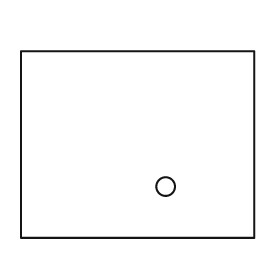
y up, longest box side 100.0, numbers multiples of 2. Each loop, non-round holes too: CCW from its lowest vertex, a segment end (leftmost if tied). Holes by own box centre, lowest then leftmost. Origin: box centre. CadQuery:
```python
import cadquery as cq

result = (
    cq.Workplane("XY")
    .moveTo(-50.0, -40.0)
    .lineTo(50.0, -40.0)
    .lineTo(50.0, 40.0)
    .lineTo(-50.0, 40.0)
    .close()
    .moveTo(12.0, -18.0)
    .circle(4.0)
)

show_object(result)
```